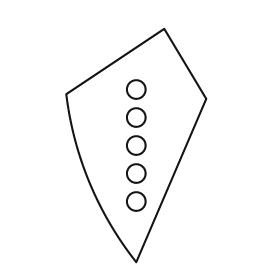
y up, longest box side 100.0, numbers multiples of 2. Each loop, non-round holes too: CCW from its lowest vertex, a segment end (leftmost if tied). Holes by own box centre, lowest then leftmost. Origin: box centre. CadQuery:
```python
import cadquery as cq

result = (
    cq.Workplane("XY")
    .moveTo(0.0, -50.0)
    .lineTo(30.0, 20.0)
    .lineTo(12.0, 50.0)
    .lineTo(-30.0, 22.0)
    .threePointArc((-20.0, -16.0), (0.0, -50.0))
    .close()
    .moveTo(0.0, -24.0)
    .circle(4.0)
    .moveTo(0.0, -12.0)
    .circle(4.0)
    .moveTo(0.0, 0.0)
    .circle(4.0)
    .moveTo(0.0, 12.0)
    .circle(4.0)
    .moveTo(0.0, 24.0)
    .circle(4.0)
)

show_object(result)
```